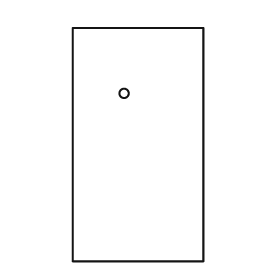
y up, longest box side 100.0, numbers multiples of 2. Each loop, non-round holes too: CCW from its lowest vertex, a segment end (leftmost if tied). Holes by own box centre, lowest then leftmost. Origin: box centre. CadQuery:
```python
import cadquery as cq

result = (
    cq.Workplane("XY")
    .moveTo(-28.0, -50.0)
    .lineTo(28.0, -50.0)
    .lineTo(28.0, 50.0)
    .lineTo(-28.0, 50.0)
    .close()
    .moveTo(-6.0, 22.0)
    .circle(2.0)
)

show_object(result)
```